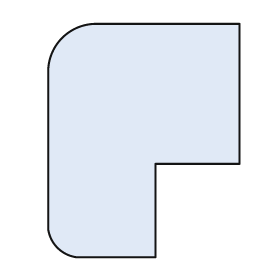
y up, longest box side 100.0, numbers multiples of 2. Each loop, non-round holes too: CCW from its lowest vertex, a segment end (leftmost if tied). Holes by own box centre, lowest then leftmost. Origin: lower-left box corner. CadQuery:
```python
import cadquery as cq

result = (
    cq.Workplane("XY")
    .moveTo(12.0, 0.0)
    .lineTo(46.0, 0.0)
    .lineTo(46.0, 40.0)
    .lineTo(82.0, 40.0)
    .lineTo(82.0, 100.0)
    .lineTo(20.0, 100.0)
    .threePointArc((6.0, 94.0), (0.0, 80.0))
    .lineTo(0.0, 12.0)
    .threePointArc((4.0, 4.0), (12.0, 0.0))
    .close()
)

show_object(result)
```